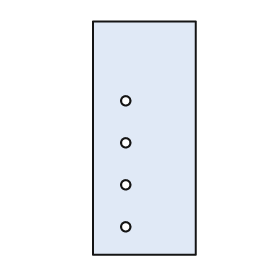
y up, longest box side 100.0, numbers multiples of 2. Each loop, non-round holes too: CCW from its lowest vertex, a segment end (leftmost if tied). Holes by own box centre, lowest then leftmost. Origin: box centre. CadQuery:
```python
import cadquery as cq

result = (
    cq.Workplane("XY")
    .moveTo(-22.0, -50.0)
    .lineTo(22.0, -50.0)
    .lineTo(22.0, 50.0)
    .lineTo(-22.0, 50.0)
    .close()
    .moveTo(-8.0, -38.0)
    .circle(2.0)
    .moveTo(-8.0, -20.0)
    .circle(2.0)
    .moveTo(-8.0, -2.0)
    .circle(2.0)
    .moveTo(-8.0, 16.0)
    .circle(2.0)
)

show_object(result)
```